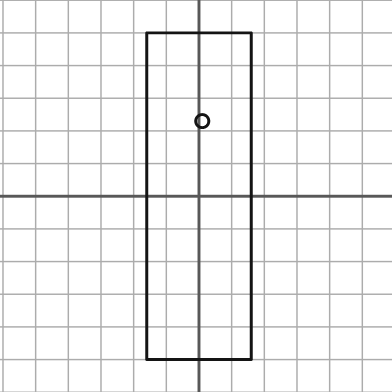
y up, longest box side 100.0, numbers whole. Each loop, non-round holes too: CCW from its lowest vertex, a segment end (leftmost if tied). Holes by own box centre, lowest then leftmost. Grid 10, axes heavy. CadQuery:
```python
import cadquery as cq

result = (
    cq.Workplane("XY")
    .moveTo(-16.0, -50.0)
    .lineTo(16.0, -50.0)
    .lineTo(16.0, 50.0)
    .lineTo(-16.0, 50.0)
    .close()
    .moveTo(1.0, 23.0)
    .circle(2.0)
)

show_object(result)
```